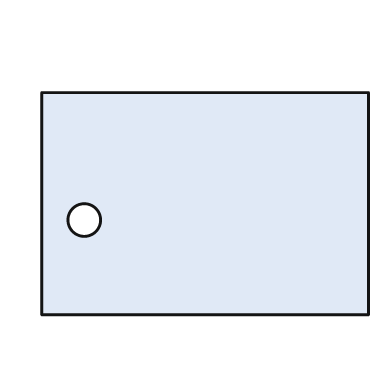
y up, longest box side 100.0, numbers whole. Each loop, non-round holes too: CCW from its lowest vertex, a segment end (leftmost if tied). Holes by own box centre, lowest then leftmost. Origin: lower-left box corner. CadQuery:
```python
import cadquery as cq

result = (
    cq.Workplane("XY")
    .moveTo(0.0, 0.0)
    .lineTo(100.0, 0.0)
    .lineTo(100.0, 68.0)
    .lineTo(0.0, 68.0)
    .close()
    .moveTo(13.0, 29.0)
    .circle(5.0)
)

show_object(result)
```